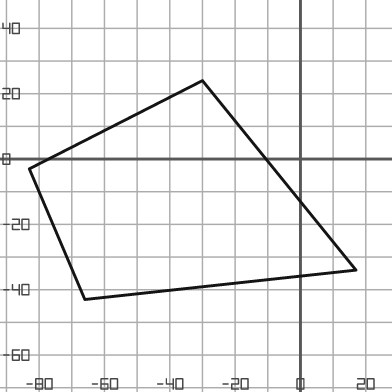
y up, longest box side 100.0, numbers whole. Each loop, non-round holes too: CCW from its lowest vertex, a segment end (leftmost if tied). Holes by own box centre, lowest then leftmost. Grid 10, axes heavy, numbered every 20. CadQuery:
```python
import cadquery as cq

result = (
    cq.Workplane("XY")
    .moveTo(-66.0, -43.0)
    .lineTo(17.0, -34.0)
    .lineTo(-30.0, 24.0)
    .lineTo(-83.0, -3.0)
    .close()
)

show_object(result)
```